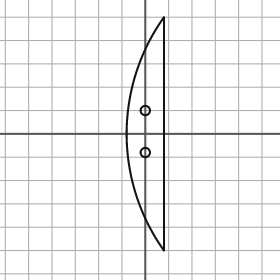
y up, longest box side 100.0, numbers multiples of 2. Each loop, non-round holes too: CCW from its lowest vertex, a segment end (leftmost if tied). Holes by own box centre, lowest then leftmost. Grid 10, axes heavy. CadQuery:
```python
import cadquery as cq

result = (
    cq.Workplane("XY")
    .moveTo(8.0, -50.0)
    .lineTo(8.0, 50.0)
    .threePointArc((-8.0, 0.0), (8.0, -50.0))
    .close()
    .moveTo(0.0, -8.0)
    .circle(2.0)
    .moveTo(0.0, 10.0)
    .circle(2.0)
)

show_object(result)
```